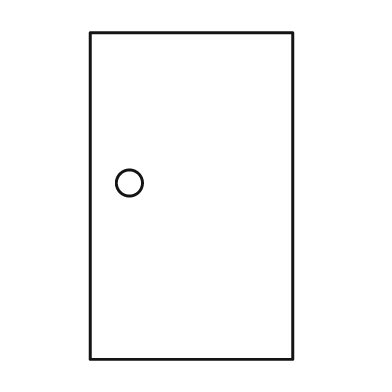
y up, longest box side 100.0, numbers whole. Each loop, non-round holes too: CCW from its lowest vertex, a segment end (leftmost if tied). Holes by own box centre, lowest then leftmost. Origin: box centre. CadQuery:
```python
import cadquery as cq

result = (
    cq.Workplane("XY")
    .moveTo(-31.0, -50.0)
    .lineTo(31.0, -50.0)
    .lineTo(31.0, 50.0)
    .lineTo(-31.0, 50.0)
    .close()
    .moveTo(-19.0, 4.0)
    .circle(4.0)
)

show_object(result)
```